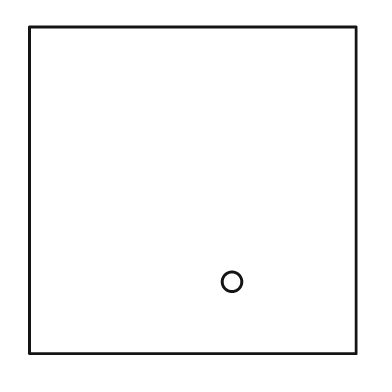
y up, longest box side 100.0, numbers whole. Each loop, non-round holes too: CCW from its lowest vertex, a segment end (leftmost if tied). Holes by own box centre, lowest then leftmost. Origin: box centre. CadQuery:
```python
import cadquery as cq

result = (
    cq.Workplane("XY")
    .moveTo(-50.0, -50.0)
    .lineTo(50.0, -50.0)
    .lineTo(50.0, 50.0)
    .lineTo(-50.0, 50.0)
    .close()
    .moveTo(12.0, -28.0)
    .circle(3.0)
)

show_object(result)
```